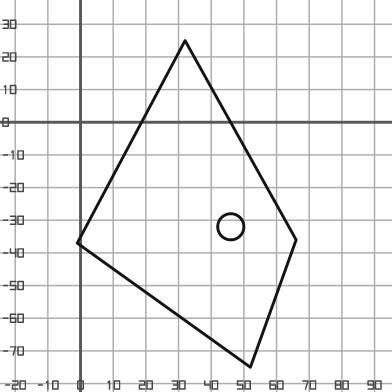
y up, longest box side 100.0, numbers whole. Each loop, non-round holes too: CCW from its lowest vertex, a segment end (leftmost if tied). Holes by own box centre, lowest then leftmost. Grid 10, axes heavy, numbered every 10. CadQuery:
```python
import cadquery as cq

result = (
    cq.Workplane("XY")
    .moveTo(52.0, -75.0)
    .lineTo(66.0, -36.0)
    .lineTo(32.0, 25.0)
    .lineTo(-1.0, -37.0)
    .close()
    .moveTo(46.0, -32.0)
    .circle(4.0)
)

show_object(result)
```